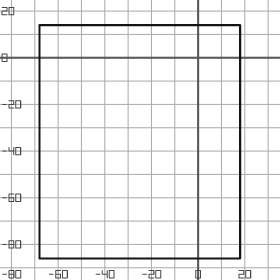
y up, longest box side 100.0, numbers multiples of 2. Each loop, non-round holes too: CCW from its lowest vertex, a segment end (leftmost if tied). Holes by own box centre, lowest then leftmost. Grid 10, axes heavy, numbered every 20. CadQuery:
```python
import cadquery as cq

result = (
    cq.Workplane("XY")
    .moveTo(-68.0, -86.0)
    .lineTo(18.0, -86.0)
    .lineTo(18.0, 14.0)
    .lineTo(-68.0, 14.0)
    .close()
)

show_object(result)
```